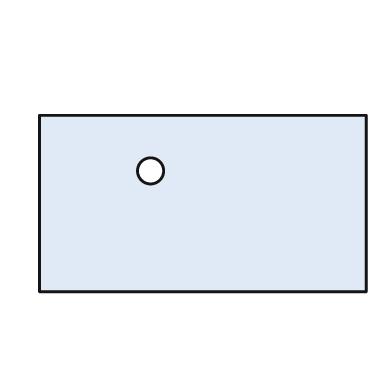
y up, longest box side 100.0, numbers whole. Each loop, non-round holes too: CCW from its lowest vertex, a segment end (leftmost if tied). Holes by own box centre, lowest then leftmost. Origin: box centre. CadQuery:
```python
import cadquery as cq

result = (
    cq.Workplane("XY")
    .moveTo(-50.0, -27.0)
    .lineTo(50.0, -27.0)
    .lineTo(50.0, 27.0)
    .lineTo(-50.0, 27.0)
    .close()
    .moveTo(-16.0, 10.0)
    .circle(4.0)
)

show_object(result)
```